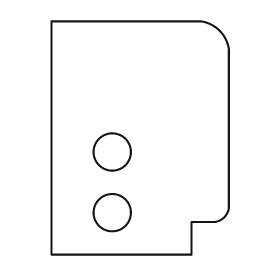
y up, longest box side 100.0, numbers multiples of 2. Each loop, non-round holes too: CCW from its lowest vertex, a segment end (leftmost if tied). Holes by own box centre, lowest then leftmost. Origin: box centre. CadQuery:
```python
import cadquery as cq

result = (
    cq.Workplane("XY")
    .moveTo(-38.0, -50.0)
    .lineTo(22.0, -50.0)
    .lineTo(22.0, -36.0)
    .lineTo(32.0, -36.0)
    .threePointArc((36.0, -34.0), (38.0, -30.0))
    .lineTo(38.0, 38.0)
    .threePointArc((34.0, 46.0), (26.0, 50.0))
    .lineTo(-38.0, 50.0)
    .close()
    .moveTo(-12.0, -32.0)
    .circle(8.0)
    .moveTo(-12.0, -6.0)
    .circle(8.0)
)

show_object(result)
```